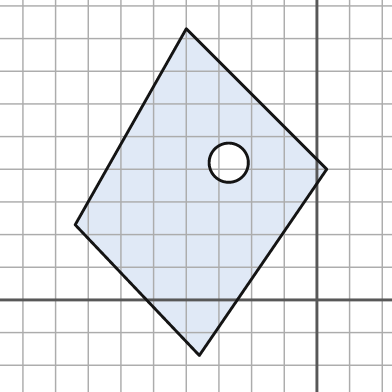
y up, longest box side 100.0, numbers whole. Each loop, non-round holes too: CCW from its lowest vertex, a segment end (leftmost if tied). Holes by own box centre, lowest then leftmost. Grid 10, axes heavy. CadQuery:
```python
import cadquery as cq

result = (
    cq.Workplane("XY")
    .moveTo(-36.0, -17.0)
    .lineTo(3.0, 40.0)
    .lineTo(-40.0, 83.0)
    .lineTo(-74.0, 23.0)
    .close()
    .moveTo(-27.0, 42.0)
    .circle(6.0)
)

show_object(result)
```